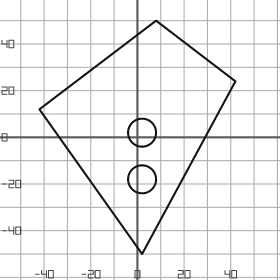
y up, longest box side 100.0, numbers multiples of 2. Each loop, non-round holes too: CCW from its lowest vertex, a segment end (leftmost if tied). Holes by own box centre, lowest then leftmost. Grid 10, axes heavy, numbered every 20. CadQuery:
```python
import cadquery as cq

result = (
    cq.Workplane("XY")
    .moveTo(2.0, -50.0)
    .lineTo(42.0, 24.0)
    .lineTo(8.0, 50.0)
    .lineTo(-42.0, 12.0)
    .close()
    .moveTo(2.0, -18.0)
    .circle(6.0)
    .moveTo(2.0, 2.0)
    .circle(6.0)
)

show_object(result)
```